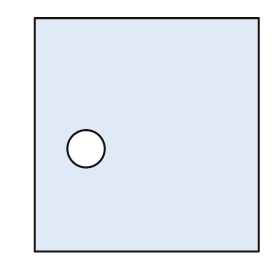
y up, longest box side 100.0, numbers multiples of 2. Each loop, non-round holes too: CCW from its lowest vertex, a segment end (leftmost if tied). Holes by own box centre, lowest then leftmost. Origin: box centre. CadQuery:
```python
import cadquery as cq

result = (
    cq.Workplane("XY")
    .moveTo(-48.0, -50.0)
    .lineTo(48.0, -50.0)
    .lineTo(48.0, 50.0)
    .lineTo(-48.0, 50.0)
    .close()
    .moveTo(-26.0, -6.0)
    .circle(8.0)
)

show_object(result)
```